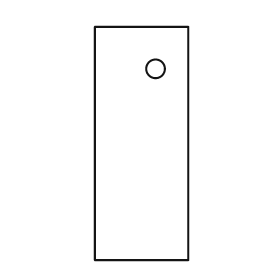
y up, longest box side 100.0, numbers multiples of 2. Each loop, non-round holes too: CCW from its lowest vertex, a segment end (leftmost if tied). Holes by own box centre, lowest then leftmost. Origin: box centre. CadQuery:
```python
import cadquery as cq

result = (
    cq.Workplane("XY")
    .moveTo(-20.0, -50.0)
    .lineTo(20.0, -50.0)
    .lineTo(20.0, 50.0)
    .lineTo(-20.0, 50.0)
    .close()
    .moveTo(6.0, 32.0)
    .circle(4.0)
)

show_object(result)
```